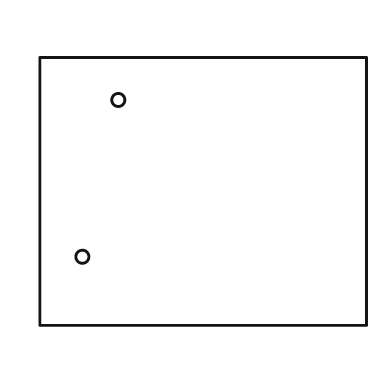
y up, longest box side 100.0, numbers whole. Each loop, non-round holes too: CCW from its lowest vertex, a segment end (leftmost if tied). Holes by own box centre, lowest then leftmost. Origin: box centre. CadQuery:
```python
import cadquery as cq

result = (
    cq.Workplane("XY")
    .moveTo(-50.0, -41.0)
    .lineTo(50.0, -41.0)
    .lineTo(50.0, 41.0)
    .lineTo(-50.0, 41.0)
    .close()
    .moveTo(-37.0, -20.0)
    .circle(2.0)
    .moveTo(-26.0, 28.0)
    .circle(2.0)
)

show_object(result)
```